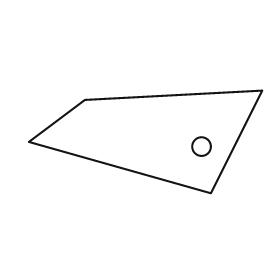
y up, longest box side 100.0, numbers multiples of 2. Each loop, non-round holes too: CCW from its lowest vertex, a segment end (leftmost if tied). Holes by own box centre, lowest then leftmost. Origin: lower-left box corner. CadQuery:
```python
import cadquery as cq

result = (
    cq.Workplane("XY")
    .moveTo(78.0, 0.0)
    .lineTo(100.0, 44.0)
    .lineTo(24.0, 40.0)
    .lineTo(0.0, 22.0)
    .close()
    .moveTo(74.0, 20.0)
    .circle(4.0)
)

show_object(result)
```